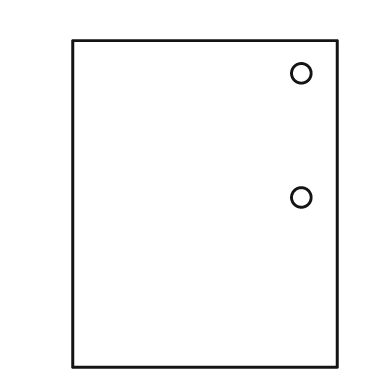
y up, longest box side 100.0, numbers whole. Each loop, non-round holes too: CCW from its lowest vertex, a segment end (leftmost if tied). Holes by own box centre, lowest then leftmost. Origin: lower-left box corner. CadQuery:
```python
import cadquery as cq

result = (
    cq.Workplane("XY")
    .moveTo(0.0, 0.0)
    .lineTo(81.0, 0.0)
    .lineTo(81.0, 100.0)
    .lineTo(0.0, 100.0)
    .close()
    .moveTo(70.0, 52.0)
    .circle(3.0)
    .moveTo(70.0, 90.0)
    .circle(3.0)
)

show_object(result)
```